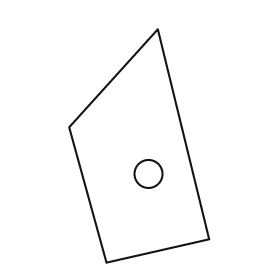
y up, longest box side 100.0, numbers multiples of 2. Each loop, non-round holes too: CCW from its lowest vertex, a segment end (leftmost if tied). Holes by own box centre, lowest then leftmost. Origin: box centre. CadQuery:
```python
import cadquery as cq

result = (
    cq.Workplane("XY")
    .moveTo(-14.0, -50.0)
    .lineTo(30.0, -40.0)
    .lineTo(8.0, 50.0)
    .lineTo(-30.0, 8.0)
    .close()
    .moveTo(4.0, -12.0)
    .circle(6.0)
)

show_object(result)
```